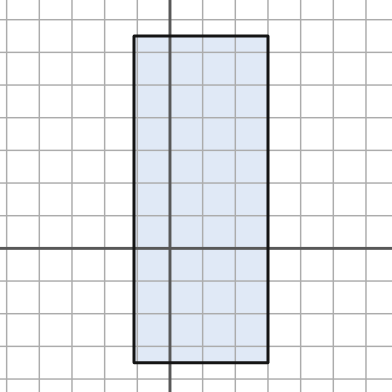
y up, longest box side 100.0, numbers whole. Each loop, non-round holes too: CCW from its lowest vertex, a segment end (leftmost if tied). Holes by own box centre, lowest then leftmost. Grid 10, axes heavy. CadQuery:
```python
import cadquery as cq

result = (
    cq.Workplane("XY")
    .moveTo(-11.0, -35.0)
    .lineTo(30.0, -35.0)
    .lineTo(30.0, 65.0)
    .lineTo(-11.0, 65.0)
    .close()
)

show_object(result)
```